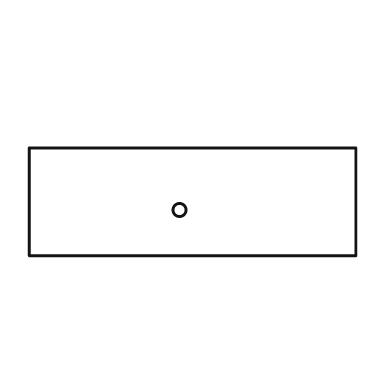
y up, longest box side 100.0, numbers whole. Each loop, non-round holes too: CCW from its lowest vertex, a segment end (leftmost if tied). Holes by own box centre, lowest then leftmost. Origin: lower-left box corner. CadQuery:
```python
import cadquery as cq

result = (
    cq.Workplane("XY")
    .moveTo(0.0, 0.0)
    .lineTo(100.0, 0.0)
    .lineTo(100.0, 33.0)
    .lineTo(0.0, 33.0)
    .close()
    .moveTo(46.0, 14.0)
    .circle(2.0)
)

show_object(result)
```